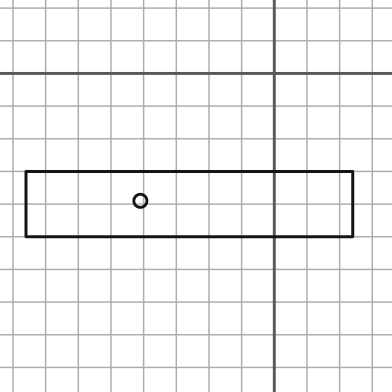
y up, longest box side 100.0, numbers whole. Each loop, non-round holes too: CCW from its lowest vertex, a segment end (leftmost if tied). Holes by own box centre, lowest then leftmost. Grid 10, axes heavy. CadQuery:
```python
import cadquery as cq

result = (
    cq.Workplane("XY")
    .moveTo(-76.0, -50.0)
    .lineTo(24.0, -50.0)
    .lineTo(24.0, -30.0)
    .lineTo(-76.0, -30.0)
    .close()
    .moveTo(-41.0, -39.0)
    .circle(2.0)
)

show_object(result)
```